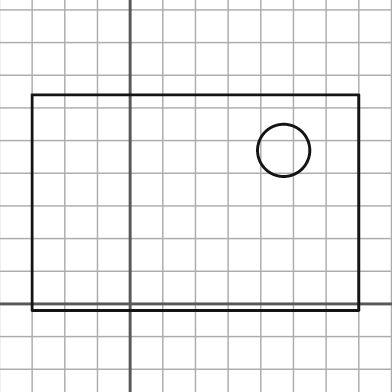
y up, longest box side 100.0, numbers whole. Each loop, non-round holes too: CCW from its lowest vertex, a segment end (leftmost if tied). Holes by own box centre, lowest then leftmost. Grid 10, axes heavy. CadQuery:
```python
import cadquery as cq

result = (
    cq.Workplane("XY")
    .moveTo(-30.0, -2.0)
    .lineTo(70.0, -2.0)
    .lineTo(70.0, 64.0)
    .lineTo(-30.0, 64.0)
    .close()
    .moveTo(47.0, 47.0)
    .circle(8.0)
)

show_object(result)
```